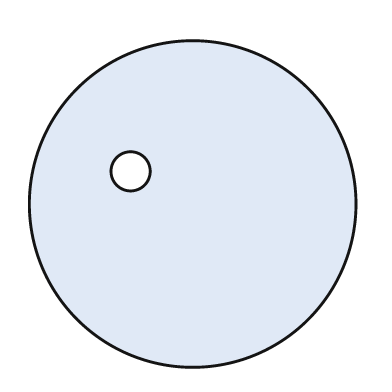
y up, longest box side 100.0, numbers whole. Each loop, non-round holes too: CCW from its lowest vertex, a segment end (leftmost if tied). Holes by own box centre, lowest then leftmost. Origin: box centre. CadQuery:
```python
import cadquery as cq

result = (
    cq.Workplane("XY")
    .moveTo(0.0, 0.0)
    .circle(50.0)
    .moveTo(-19.0, 10.0)
    .circle(6.0)
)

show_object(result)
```